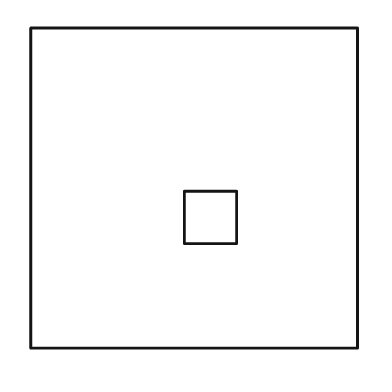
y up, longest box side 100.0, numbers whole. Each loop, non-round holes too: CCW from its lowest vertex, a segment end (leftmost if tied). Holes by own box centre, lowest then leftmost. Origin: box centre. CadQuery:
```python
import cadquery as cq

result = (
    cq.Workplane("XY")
    .moveTo(-50.0, -49.0)
    .lineTo(50.0, -49.0)
    .lineTo(50.0, 49.0)
    .lineTo(-50.0, 49.0)
    .close()
    .moveTo(-3.0, -17.0)
    .lineTo(13.0, -17.0)
    .lineTo(13.0, -1.0)
    .lineTo(-3.0, -1.0)
    .close()
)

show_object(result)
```